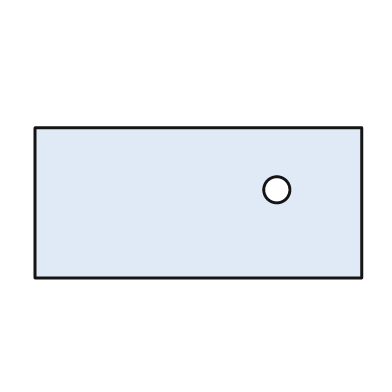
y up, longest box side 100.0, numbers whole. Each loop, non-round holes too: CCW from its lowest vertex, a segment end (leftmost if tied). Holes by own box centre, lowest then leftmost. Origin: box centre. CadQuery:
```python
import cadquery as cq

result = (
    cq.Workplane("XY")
    .moveTo(-50.0, -23.0)
    .lineTo(50.0, -23.0)
    .lineTo(50.0, 23.0)
    .lineTo(-50.0, 23.0)
    .close()
    .moveTo(24.0, 4.0)
    .circle(4.0)
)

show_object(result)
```